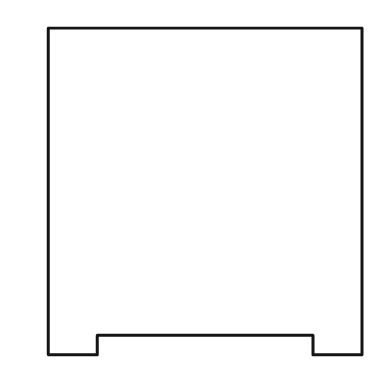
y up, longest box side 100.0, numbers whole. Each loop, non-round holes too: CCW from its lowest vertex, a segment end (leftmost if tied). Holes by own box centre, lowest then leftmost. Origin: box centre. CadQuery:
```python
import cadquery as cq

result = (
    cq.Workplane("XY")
    .moveTo(-48.0, -50.0)
    .lineTo(-33.0, -50.0)
    .lineTo(-33.0, -44.0)
    .lineTo(33.0, -44.0)
    .lineTo(33.0, -50.0)
    .lineTo(48.0, -50.0)
    .lineTo(48.0, 50.0)
    .lineTo(-48.0, 50.0)
    .close()
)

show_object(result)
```